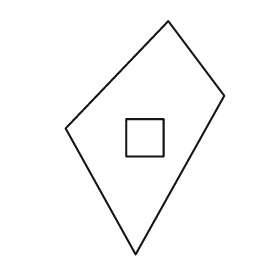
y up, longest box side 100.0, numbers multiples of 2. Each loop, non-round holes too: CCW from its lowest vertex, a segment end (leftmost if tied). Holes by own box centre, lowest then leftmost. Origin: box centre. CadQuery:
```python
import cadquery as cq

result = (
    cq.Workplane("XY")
    .moveTo(-4.0, -50.0)
    .lineTo(34.0, 18.0)
    .lineTo(10.0, 50.0)
    .lineTo(-34.0, 4.0)
    .close()
    .moveTo(-8.0, -8.0)
    .lineTo(8.0, -8.0)
    .lineTo(8.0, 8.0)
    .lineTo(-8.0, 8.0)
    .close()
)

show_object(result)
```